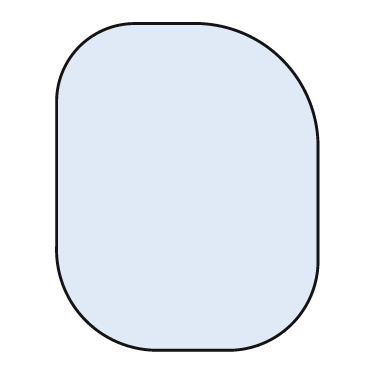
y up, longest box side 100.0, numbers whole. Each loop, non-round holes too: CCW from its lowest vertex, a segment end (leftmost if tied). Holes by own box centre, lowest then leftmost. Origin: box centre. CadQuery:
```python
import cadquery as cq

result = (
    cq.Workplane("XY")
    .moveTo(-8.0, -50.0)
    .lineTo(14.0, -50.0)
    .threePointArc((32.0, -42.0), (40.0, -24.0))
    .lineTo(40.0, 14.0)
    .threePointArc((29.0, 39.0), (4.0, 50.0))
    .lineTo(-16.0, 50.0)
    .threePointArc((-33.0, 43.0), (-40.0, 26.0))
    .lineTo(-40.0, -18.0)
    .threePointArc((-31.0, -41.0), (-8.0, -50.0))
    .close()
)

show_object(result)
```